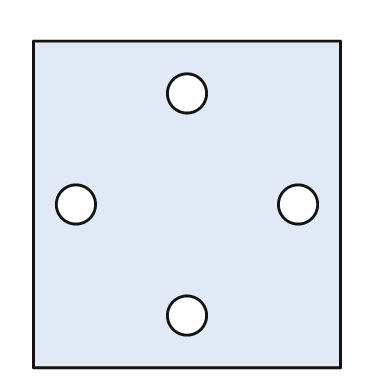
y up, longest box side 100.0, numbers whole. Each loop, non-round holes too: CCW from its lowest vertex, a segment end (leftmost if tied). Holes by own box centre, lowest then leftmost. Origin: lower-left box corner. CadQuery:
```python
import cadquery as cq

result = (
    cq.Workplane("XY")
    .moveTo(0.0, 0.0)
    .lineTo(94.0, 0.0)
    .lineTo(94.0, 100.0)
    .lineTo(0.0, 100.0)
    .close()
    .moveTo(47.0, 16.0)
    .circle(6.0)
    .moveTo(13.0, 50.0)
    .circle(6.0)
    .moveTo(81.0, 50.0)
    .circle(6.0)
    .moveTo(47.0, 84.0)
    .circle(6.0)
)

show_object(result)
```